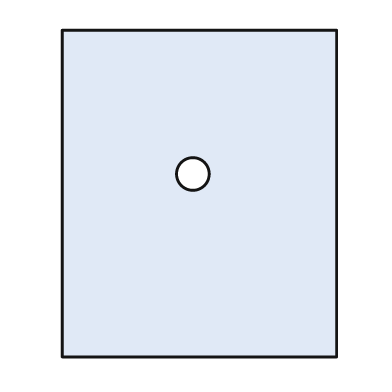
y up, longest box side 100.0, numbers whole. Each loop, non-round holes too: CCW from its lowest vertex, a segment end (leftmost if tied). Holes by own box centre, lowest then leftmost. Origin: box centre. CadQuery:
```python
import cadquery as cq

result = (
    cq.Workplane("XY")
    .moveTo(-42.0, -50.0)
    .lineTo(42.0, -50.0)
    .lineTo(42.0, 50.0)
    .lineTo(-42.0, 50.0)
    .close()
    .moveTo(-2.0, 6.0)
    .circle(5.0)
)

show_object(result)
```